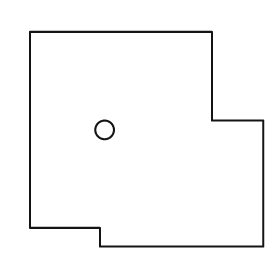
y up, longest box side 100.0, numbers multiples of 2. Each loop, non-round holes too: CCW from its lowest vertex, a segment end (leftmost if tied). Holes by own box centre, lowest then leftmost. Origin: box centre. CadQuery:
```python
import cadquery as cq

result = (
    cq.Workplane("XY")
    .moveTo(-20.0, -46.0)
    .lineTo(50.0, -46.0)
    .lineTo(50.0, 8.0)
    .lineTo(28.0, 8.0)
    .lineTo(28.0, 46.0)
    .lineTo(-50.0, 46.0)
    .lineTo(-50.0, -38.0)
    .lineTo(-20.0, -38.0)
    .close()
    .moveTo(-18.0, 4.0)
    .circle(4.0)
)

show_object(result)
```